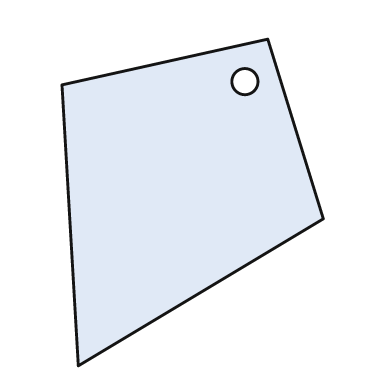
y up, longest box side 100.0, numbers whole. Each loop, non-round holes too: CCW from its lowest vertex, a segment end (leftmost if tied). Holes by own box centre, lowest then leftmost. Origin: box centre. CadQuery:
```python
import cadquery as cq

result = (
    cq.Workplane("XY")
    .moveTo(-35.0, -50.0)
    .lineTo(40.0, -5.0)
    .lineTo(23.0, 50.0)
    .lineTo(-40.0, 36.0)
    .close()
    .moveTo(16.0, 37.0)
    .circle(4.0)
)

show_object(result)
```